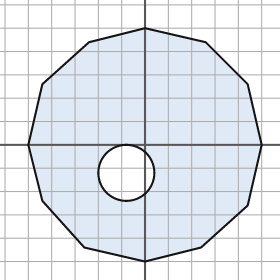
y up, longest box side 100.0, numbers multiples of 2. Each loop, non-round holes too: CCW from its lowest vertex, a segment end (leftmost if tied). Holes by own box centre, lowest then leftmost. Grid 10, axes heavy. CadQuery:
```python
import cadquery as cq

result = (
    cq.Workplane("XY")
    .moveTo(0.0, -50.0)
    .lineTo(24.0, -44.0)
    .lineTo(44.0, -26.0)
    .lineTo(50.0, 0.0)
    .lineTo(44.0, 26.0)
    .lineTo(26.0, 44.0)
    .lineTo(0.0, 50.0)
    .lineTo(-24.0, 44.0)
    .lineTo(-44.0, 26.0)
    .lineTo(-50.0, 0.0)
    .lineTo(-44.0, -24.0)
    .lineTo(-26.0, -44.0)
    .close()
    .moveTo(-8.0, -12.0)
    .circle(12.0)
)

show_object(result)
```